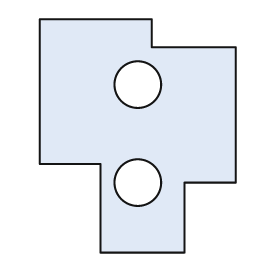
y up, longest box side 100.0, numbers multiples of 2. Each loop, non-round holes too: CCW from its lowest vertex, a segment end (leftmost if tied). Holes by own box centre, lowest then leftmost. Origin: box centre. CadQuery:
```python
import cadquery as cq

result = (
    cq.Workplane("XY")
    .moveTo(-16.0, -50.0)
    .lineTo(20.0, -50.0)
    .lineTo(20.0, -20.0)
    .lineTo(42.0, -20.0)
    .lineTo(42.0, 38.0)
    .lineTo(6.0, 38.0)
    .lineTo(6.0, 50.0)
    .lineTo(-42.0, 50.0)
    .lineTo(-42.0, -12.0)
    .lineTo(-16.0, -12.0)
    .close()
    .moveTo(0.0, -20.0)
    .circle(10.0)
    .moveTo(0.0, 22.0)
    .circle(10.0)
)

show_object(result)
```